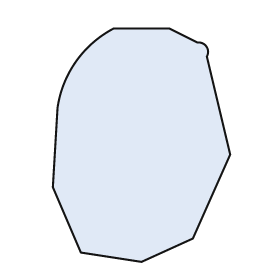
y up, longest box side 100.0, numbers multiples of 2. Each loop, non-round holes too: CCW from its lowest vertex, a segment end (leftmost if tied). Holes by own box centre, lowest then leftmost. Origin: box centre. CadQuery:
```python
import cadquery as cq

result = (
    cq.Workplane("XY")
    .moveTo(0.0, -50.0)
    .lineTo(22.0, -40.0)
    .lineTo(38.0, -4.0)
    .lineTo(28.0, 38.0)
    .threePointArc((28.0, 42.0), (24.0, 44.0))
    .lineTo(12.0, 50.0)
    .lineTo(-12.0, 50.0)
    .threePointArc((-28.0, 36.0), (-36.0, 16.0))
    .lineTo(-38.0, -18.0)
    .lineTo(-26.0, -46.0)
    .close()
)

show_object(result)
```